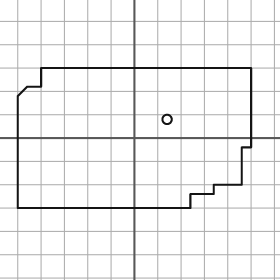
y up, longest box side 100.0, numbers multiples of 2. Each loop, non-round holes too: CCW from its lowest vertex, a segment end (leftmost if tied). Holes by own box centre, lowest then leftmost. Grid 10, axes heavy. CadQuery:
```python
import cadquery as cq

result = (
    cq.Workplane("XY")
    .moveTo(-50.0, -30.0)
    .lineTo(24.0, -30.0)
    .lineTo(24.0, -24.0)
    .lineTo(34.0, -24.0)
    .lineTo(34.0, -20.0)
    .lineTo(46.0, -20.0)
    .lineTo(46.0, -4.0)
    .lineTo(50.0, -4.0)
    .lineTo(50.0, 30.0)
    .lineTo(-40.0, 30.0)
    .lineTo(-40.0, 22.0)
    .lineTo(-46.0, 22.0)
    .lineTo(-50.0, 18.0)
    .close()
    .moveTo(14.0, 8.0)
    .circle(2.0)
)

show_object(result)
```